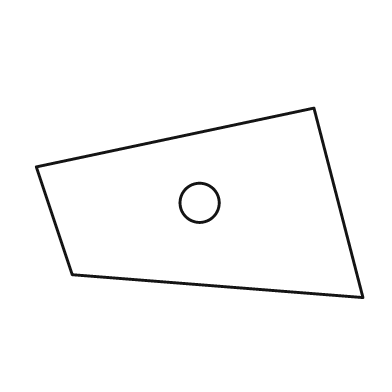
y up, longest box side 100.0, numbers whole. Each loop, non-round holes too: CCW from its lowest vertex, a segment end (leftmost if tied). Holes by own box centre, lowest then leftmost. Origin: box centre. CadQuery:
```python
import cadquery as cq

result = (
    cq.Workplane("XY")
    .moveTo(50.0, -29.0)
    .lineTo(35.0, 29.0)
    .lineTo(-50.0, 11.0)
    .lineTo(-39.0, -22.0)
    .close()
    .moveTo(0.0, 0.0)
    .circle(6.0)
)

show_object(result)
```